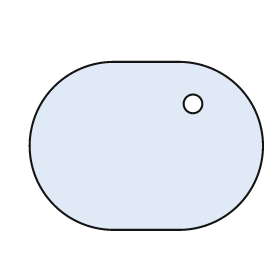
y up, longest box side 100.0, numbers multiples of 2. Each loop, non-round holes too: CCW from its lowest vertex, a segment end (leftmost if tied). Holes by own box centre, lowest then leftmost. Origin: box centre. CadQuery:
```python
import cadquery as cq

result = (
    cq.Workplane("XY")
    .moveTo(-14.0, -36.0)
    .lineTo(14.0, -36.0)
    .threePointArc((50.0, 0.0), (14.0, 36.0))
    .lineTo(-14.0, 36.0)
    .threePointArc((-50.0, 0.0), (-14.0, -36.0))
    .close()
    .moveTo(20.0, 18.0)
    .circle(4.0)
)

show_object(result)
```